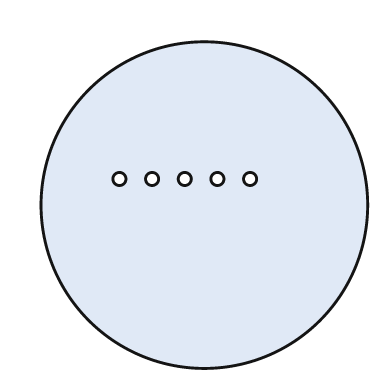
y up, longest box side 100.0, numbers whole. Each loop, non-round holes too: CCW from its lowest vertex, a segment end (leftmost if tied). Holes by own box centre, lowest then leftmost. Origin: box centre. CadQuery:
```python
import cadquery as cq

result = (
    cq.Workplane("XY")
    .moveTo(0.0, 0.0)
    .circle(50.0)
    .moveTo(-26.0, 8.0)
    .circle(2.0)
    .moveTo(-16.0, 8.0)
    .circle(2.0)
    .moveTo(-6.0, 8.0)
    .circle(2.0)
    .moveTo(4.0, 8.0)
    .circle(2.0)
    .moveTo(14.0, 8.0)
    .circle(2.0)
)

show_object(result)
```